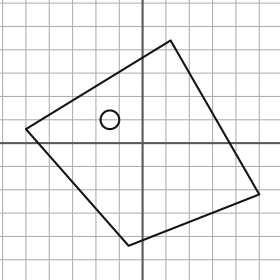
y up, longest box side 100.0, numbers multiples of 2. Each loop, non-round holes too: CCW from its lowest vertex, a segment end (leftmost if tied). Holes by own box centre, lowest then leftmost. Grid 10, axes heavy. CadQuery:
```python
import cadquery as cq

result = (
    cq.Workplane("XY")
    .moveTo(-6.0, -44.0)
    .lineTo(50.0, -22.0)
    .lineTo(12.0, 44.0)
    .lineTo(-50.0, 6.0)
    .close()
    .moveTo(-14.0, 10.0)
    .circle(4.0)
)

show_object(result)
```